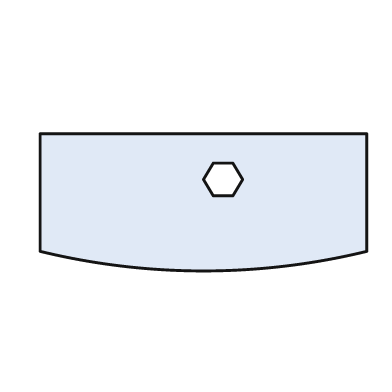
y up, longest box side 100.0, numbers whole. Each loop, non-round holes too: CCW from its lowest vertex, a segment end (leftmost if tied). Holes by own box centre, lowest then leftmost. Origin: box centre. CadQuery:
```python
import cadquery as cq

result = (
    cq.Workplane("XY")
    .moveTo(-50.0, -15.0)
    .threePointArc((0.0, -21.0), (50.0, -15.0))
    .lineTo(50.0, 21.0)
    .lineTo(-50.0, 21.0)
    .close()
    .moveTo(3.0, 2.0)
    .lineTo(9.0, 2.0)
    .lineTo(12.0, 7.0)
    .lineTo(9.0, 12.0)
    .lineTo(3.0, 12.0)
    .lineTo(0.0, 7.0)
    .close()
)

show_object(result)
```